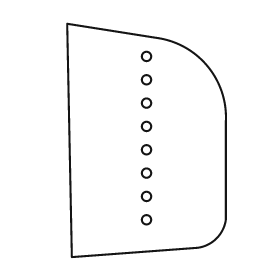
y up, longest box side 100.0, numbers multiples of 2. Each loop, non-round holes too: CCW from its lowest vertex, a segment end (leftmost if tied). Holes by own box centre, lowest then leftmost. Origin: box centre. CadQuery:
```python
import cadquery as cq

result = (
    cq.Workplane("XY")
    .moveTo(-32.0, -50.0)
    .lineTo(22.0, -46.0)
    .threePointArc((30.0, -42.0), (34.0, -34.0))
    .lineTo(34.0, 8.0)
    .threePointArc((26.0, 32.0), (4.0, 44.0))
    .lineTo(-34.0, 50.0)
    .close()
    .moveTo(0.0, -34.0)
    .circle(2.0)
    .moveTo(0.0, -24.0)
    .circle(2.0)
    .moveTo(0.0, -14.0)
    .circle(2.0)
    .moveTo(0.0, -4.0)
    .circle(2.0)
    .moveTo(0.0, 6.0)
    .circle(2.0)
    .moveTo(0.0, 16.0)
    .circle(2.0)
    .moveTo(0.0, 26.0)
    .circle(2.0)
    .moveTo(0.0, 36.0)
    .circle(2.0)
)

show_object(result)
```